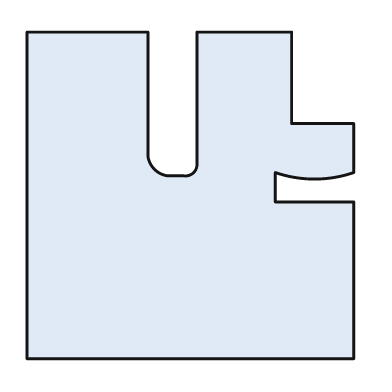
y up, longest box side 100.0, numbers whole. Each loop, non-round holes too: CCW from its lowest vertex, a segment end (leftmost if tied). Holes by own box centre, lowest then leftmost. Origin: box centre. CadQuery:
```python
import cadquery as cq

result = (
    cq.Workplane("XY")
    .moveTo(-50.0, -50.0)
    .lineTo(50.0, -50.0)
    .lineTo(50.0, -2.0)
    .lineTo(26.0, -2.0)
    .lineTo(26.0, 7.0)
    .threePointArc((38.0, 5.0), (50.0, 7.0))
    .lineTo(50.0, 22.0)
    .lineTo(31.0, 22.0)
    .lineTo(31.0, 50.0)
    .lineTo(2.0, 50.0)
    .lineTo(2.0, 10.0)
    .threePointArc((1.0, 7.0), (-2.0, 6.0))
    .lineTo(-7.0, 6.0)
    .threePointArc((-11.0, 8.0), (-13.0, 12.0))
    .lineTo(-13.0, 50.0)
    .lineTo(-50.0, 50.0)
    .close()
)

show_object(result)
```